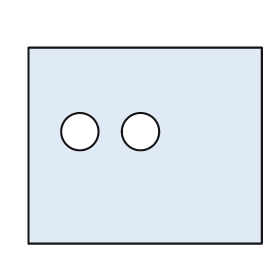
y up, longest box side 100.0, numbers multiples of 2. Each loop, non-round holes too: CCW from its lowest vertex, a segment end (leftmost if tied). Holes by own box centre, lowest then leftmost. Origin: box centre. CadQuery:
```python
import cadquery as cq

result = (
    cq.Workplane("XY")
    .moveTo(-50.0, -42.0)
    .lineTo(50.0, -42.0)
    .lineTo(50.0, 42.0)
    .lineTo(-50.0, 42.0)
    .close()
    .moveTo(-28.0, 6.0)
    .circle(8.0)
    .moveTo(-2.0, 6.0)
    .circle(8.0)
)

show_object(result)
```